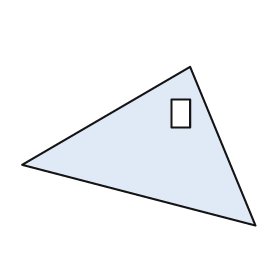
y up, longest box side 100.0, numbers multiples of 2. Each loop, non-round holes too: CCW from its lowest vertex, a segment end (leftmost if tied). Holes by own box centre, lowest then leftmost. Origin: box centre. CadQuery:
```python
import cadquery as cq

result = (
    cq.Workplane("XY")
    .moveTo(50.0, -34.0)
    .lineTo(22.0, 34.0)
    .lineTo(-50.0, -8.0)
    .close()
    .moveTo(14.0, 8.0)
    .lineTo(22.0, 8.0)
    .lineTo(22.0, 20.0)
    .lineTo(14.0, 20.0)
    .close()
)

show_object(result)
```